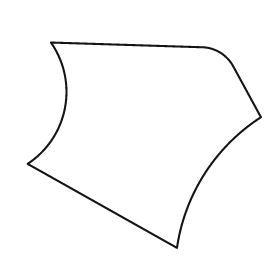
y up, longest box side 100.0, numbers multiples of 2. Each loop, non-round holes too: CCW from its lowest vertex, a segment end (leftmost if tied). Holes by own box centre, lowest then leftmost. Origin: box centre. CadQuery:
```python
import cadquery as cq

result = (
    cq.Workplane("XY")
    .moveTo(14.0, -44.0)
    .threePointArc((26.0, -12.0), (50.0, 12.0))
    .lineTo(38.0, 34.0)
    .threePointArc((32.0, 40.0), (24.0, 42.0))
    .lineTo(-40.0, 44.0)
    .threePointArc((-34.0, 16.0), (-50.0, -8.0))
    .close()
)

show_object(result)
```